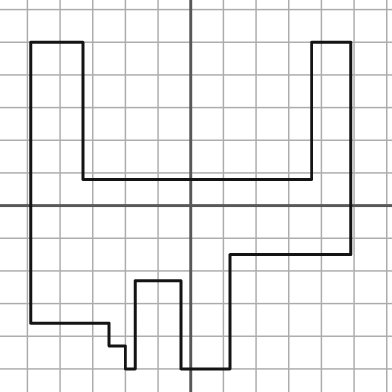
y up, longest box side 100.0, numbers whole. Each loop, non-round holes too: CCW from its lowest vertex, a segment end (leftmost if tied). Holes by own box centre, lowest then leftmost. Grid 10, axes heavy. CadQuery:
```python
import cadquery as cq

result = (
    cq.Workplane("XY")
    .moveTo(-20.0, -50.0)
    .lineTo(-17.0, -50.0)
    .lineTo(-17.0, -23.0)
    .lineTo(-3.0, -23.0)
    .lineTo(-3.0, -50.0)
    .lineTo(12.0, -50.0)
    .lineTo(12.0, -15.0)
    .lineTo(49.0, -15.0)
    .lineTo(49.0, 50.0)
    .lineTo(37.0, 50.0)
    .lineTo(37.0, 8.0)
    .lineTo(-33.0, 8.0)
    .lineTo(-33.0, 50.0)
    .lineTo(-49.0, 50.0)
    .lineTo(-49.0, -36.0)
    .lineTo(-25.0, -36.0)
    .lineTo(-25.0, -43.0)
    .lineTo(-20.0, -43.0)
    .close()
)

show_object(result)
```